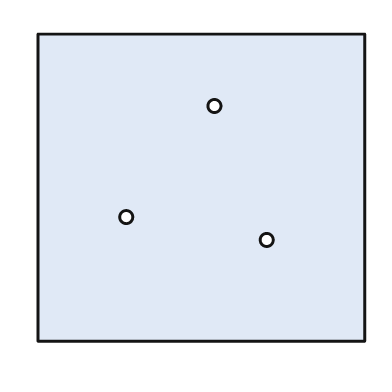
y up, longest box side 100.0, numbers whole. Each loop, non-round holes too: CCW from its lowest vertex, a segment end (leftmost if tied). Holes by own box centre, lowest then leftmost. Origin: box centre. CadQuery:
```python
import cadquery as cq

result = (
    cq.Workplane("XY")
    .moveTo(-50.0, -47.0)
    .lineTo(50.0, -47.0)
    .lineTo(50.0, 47.0)
    .lineTo(-50.0, 47.0)
    .close()
    .moveTo(20.0, -16.0)
    .circle(2.0)
    .moveTo(-23.0, -9.0)
    .circle(2.0)
    .moveTo(4.0, 25.0)
    .circle(2.0)
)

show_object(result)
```